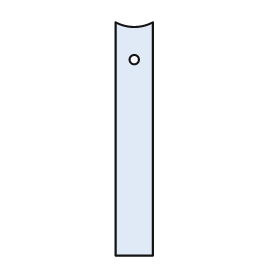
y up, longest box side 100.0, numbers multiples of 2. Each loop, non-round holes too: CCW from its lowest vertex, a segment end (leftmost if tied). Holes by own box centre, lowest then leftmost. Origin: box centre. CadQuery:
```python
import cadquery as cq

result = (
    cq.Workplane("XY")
    .moveTo(-8.0, -50.0)
    .lineTo(8.0, -50.0)
    .lineTo(8.0, 50.0)
    .threePointArc((0.0, 48.0), (-8.0, 50.0))
    .close()
    .moveTo(0.0, 34.0)
    .circle(2.0)
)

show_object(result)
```